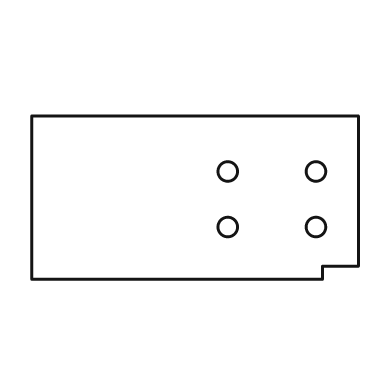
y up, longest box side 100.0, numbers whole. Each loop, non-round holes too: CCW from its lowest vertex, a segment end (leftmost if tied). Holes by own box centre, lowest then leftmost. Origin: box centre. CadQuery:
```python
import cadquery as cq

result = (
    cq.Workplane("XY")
    .moveTo(-50.0, -25.0)
    .lineTo(39.0, -25.0)
    .lineTo(39.0, -21.0)
    .lineTo(50.0, -21.0)
    .lineTo(50.0, 25.0)
    .lineTo(-50.0, 25.0)
    .close()
    .moveTo(10.0, -9.0)
    .circle(3.0)
    .moveTo(37.0, -9.0)
    .circle(3.0)
    .moveTo(10.0, 8.0)
    .circle(3.0)
    .moveTo(37.0, 8.0)
    .circle(3.0)
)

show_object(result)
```